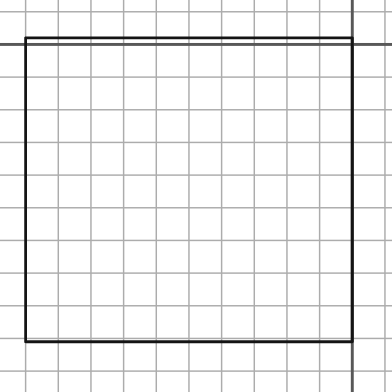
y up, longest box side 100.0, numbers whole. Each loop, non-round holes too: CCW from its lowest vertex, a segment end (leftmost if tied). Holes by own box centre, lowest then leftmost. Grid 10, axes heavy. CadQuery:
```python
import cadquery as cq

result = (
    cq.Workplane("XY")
    .moveTo(-100.0, -91.0)
    .lineTo(0.0, -91.0)
    .lineTo(0.0, 2.0)
    .lineTo(-100.0, 2.0)
    .close()
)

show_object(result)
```